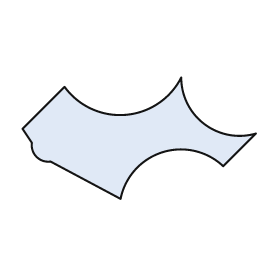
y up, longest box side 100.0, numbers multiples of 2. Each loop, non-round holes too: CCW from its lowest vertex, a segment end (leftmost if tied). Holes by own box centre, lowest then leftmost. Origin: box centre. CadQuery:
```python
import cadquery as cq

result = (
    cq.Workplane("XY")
    .moveTo(-8.0, -26.0)
    .threePointArc((10.0, -6.0), (36.0, -12.0))
    .lineTo(50.0, 2.0)
    .threePointArc((28.0, 6.0), (18.0, 26.0))
    .threePointArc((-6.0, 10.0), (-32.0, 22.0))
    .lineTo(-50.0, 4.0)
    .lineTo(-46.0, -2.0)
    .threePointArc((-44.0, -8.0), (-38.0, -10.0))
    .close()
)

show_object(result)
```